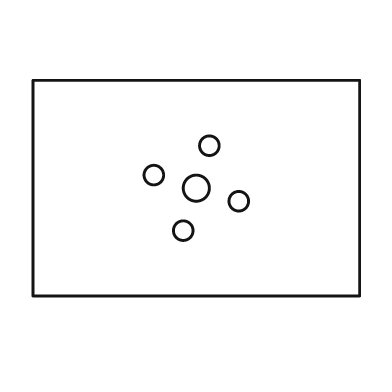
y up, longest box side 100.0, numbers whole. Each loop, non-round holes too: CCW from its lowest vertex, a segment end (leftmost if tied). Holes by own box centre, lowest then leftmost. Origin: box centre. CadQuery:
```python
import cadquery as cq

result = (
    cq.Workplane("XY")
    .moveTo(-50.0, -33.0)
    .lineTo(50.0, -33.0)
    .lineTo(50.0, 33.0)
    .lineTo(-50.0, 33.0)
    .close()
    .moveTo(-4.0, -13.0)
    .circle(3.0)
    .moveTo(13.0, -4.0)
    .circle(3.0)
    .moveTo(0.0, 0.0)
    .circle(4.0)
    .moveTo(-13.0, 4.0)
    .circle(3.0)
    .moveTo(4.0, 13.0)
    .circle(3.0)
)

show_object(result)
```